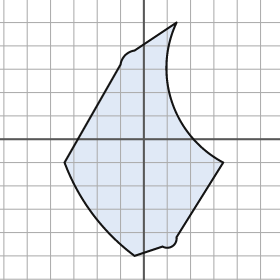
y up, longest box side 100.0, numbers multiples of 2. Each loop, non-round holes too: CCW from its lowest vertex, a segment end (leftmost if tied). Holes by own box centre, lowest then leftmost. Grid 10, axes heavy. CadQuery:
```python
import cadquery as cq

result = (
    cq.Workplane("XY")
    .moveTo(-4.0, -50.0)
    .lineTo(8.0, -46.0)
    .threePointArc((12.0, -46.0), (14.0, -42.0))
    .lineTo(34.0, -10.0)
    .threePointArc((12.0, 16.0), (14.0, 50.0))
    .lineTo(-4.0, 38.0)
    .threePointArc((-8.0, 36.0), (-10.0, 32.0))
    .lineTo(-34.0, -10.0)
    .threePointArc((-22.0, -32.0), (-4.0, -50.0))
    .close()
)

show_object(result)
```